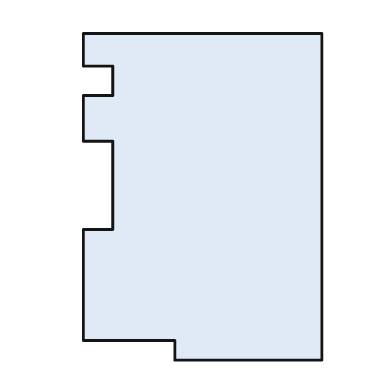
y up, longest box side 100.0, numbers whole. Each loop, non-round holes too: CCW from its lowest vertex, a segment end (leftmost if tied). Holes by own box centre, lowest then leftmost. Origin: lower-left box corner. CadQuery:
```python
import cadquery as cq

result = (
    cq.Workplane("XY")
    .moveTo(28.0, 0.0)
    .lineTo(73.0, 0.0)
    .lineTo(73.0, 100.0)
    .lineTo(0.0, 100.0)
    .lineTo(0.0, 90.0)
    .lineTo(9.0, 90.0)
    .lineTo(9.0, 81.0)
    .lineTo(0.0, 81.0)
    .lineTo(0.0, 67.0)
    .lineTo(9.0, 67.0)
    .lineTo(9.0, 40.0)
    .lineTo(0.0, 40.0)
    .lineTo(0.0, 6.0)
    .lineTo(28.0, 6.0)
    .close()
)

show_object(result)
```